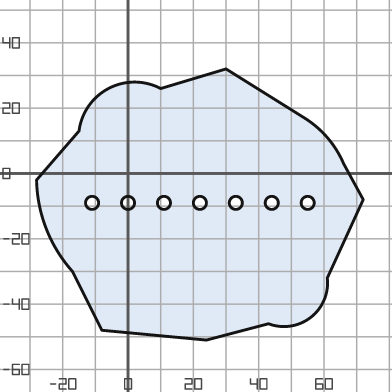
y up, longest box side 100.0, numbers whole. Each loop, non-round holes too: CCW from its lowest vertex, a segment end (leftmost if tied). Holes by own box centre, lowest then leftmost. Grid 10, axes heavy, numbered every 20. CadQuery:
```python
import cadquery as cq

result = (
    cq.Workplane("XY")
    .moveTo(24.0, -51.0)
    .lineTo(43.0, -46.0)
    .threePointArc((56.0, -44.0), (61.0, -32.0))
    .lineTo(72.0, -8.0)
    .lineTo(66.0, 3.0)
    .threePointArc((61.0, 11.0), (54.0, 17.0))
    .lineTo(30.0, 32.0)
    .lineTo(10.0, 26.0)
    .threePointArc((-6.0, 26.0), (-15.0, 13.0))
    .lineTo(-28.0, -2.0)
    .threePointArc((-25.0, -17.0), (-17.0, -30.0))
    .lineTo(-8.0, -48.0)
    .close()
    .moveTo(-11.0, -9.0)
    .circle(2.0)
    .moveTo(0.0, -9.0)
    .circle(2.0)
    .moveTo(11.0, -9.0)
    .circle(2.0)
    .moveTo(22.0, -9.0)
    .circle(2.0)
    .moveTo(33.0, -9.0)
    .circle(2.0)
    .moveTo(44.0, -9.0)
    .circle(2.0)
    .moveTo(55.0, -9.0)
    .circle(2.0)
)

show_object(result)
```